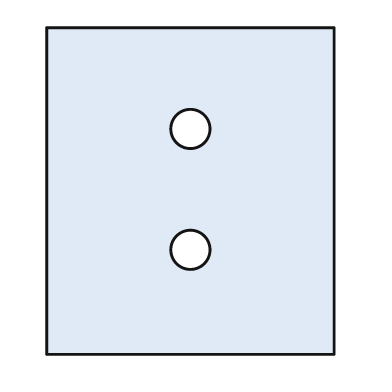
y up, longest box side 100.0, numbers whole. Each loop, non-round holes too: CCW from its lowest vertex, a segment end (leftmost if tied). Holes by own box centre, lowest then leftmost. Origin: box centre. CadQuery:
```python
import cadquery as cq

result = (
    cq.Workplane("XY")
    .moveTo(-44.0, -50.0)
    .lineTo(44.0, -50.0)
    .lineTo(44.0, 50.0)
    .lineTo(-44.0, 50.0)
    .close()
    .moveTo(0.0, -18.0)
    .circle(6.0)
    .moveTo(0.0, 19.0)
    .circle(6.0)
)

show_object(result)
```